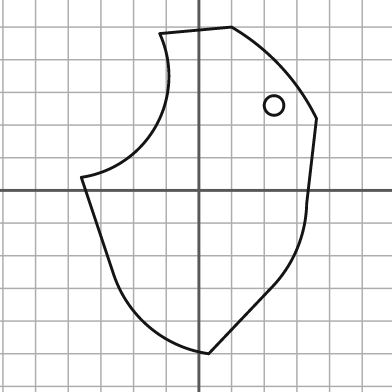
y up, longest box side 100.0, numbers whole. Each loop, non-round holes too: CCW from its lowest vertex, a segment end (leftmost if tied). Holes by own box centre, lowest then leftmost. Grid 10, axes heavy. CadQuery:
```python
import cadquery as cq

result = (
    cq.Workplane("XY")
    .moveTo(3.0, -50.0)
    .lineTo(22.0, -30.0)
    .threePointArc((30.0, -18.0), (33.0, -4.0))
    .lineTo(36.0, 22.0)
    .threePointArc((25.0, 38.0), (10.0, 50.0))
    .lineTo(-12.0, 48.0)
    .threePointArc((-13.0, 20.0), (-36.0, 4.0))
    .lineTo(-26.0, -26.0)
    .threePointArc((-15.0, -42.0), (3.0, -50.0))
    .close()
    .moveTo(23.0, 26.0)
    .circle(3.0)
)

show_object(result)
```